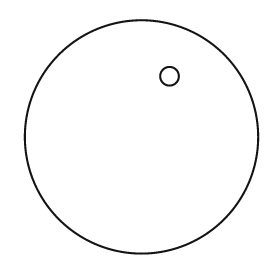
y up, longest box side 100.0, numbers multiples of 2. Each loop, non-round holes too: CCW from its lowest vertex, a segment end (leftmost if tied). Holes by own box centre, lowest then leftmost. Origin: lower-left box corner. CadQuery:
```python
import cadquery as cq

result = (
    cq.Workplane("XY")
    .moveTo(50.0, 50.0)
    .circle(50.0)
    .moveTo(62.0, 76.0)
    .circle(4.0)
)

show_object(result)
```